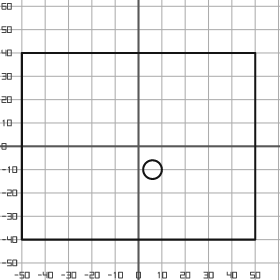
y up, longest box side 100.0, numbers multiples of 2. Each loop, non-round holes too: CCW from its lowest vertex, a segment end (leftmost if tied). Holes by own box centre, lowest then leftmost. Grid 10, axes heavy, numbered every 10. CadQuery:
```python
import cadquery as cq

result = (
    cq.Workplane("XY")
    .moveTo(-50.0, -40.0)
    .lineTo(50.0, -40.0)
    .lineTo(50.0, 40.0)
    .lineTo(-50.0, 40.0)
    .close()
    .moveTo(6.0, -10.0)
    .circle(4.0)
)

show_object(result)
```